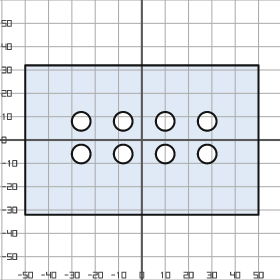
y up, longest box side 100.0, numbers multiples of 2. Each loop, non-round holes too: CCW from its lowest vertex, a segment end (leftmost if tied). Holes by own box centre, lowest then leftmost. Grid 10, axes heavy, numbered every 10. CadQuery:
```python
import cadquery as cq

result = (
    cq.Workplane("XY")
    .moveTo(-50.0, -32.0)
    .lineTo(50.0, -32.0)
    .lineTo(50.0, 32.0)
    .lineTo(-50.0, 32.0)
    .close()
    .moveTo(-26.0, -6.0)
    .circle(4.0)
    .moveTo(-8.0, -6.0)
    .circle(4.0)
    .moveTo(10.0, -6.0)
    .circle(4.0)
    .moveTo(28.0, -6.0)
    .circle(4.0)
    .moveTo(-26.0, 8.0)
    .circle(4.0)
    .moveTo(-8.0, 8.0)
    .circle(4.0)
    .moveTo(10.0, 8.0)
    .circle(4.0)
    .moveTo(28.0, 8.0)
    .circle(4.0)
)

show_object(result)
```